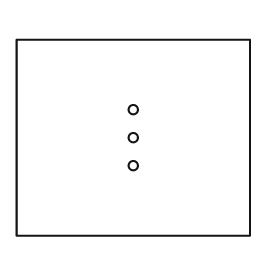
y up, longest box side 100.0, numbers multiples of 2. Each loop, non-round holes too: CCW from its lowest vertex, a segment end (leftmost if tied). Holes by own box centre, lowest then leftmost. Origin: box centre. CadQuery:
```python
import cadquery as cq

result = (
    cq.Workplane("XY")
    .moveTo(-50.0, -42.0)
    .lineTo(50.0, -42.0)
    .lineTo(50.0, 42.0)
    .lineTo(-50.0, 42.0)
    .close()
    .moveTo(0.0, -12.0)
    .circle(2.0)
    .moveTo(0.0, 0.0)
    .circle(2.0)
    .moveTo(0.0, 12.0)
    .circle(2.0)
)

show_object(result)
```